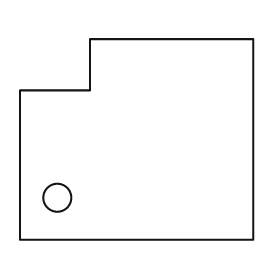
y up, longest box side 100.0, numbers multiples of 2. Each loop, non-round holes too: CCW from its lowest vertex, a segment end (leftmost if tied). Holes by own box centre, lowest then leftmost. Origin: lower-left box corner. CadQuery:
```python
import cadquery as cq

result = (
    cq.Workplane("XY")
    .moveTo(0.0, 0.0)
    .lineTo(100.0, 0.0)
    .lineTo(100.0, 86.0)
    .lineTo(30.0, 86.0)
    .lineTo(30.0, 64.0)
    .lineTo(0.0, 64.0)
    .close()
    .moveTo(16.0, 18.0)
    .circle(6.0)
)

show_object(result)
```